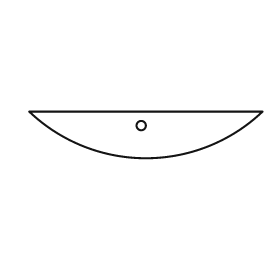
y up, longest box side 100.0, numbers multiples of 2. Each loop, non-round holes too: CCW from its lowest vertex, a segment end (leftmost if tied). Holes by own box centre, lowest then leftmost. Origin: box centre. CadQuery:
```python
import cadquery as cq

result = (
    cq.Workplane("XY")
    .moveTo(-50.0, 10.0)
    .threePointArc((0.0, -10.0), (50.0, 10.0))
    .close()
    .moveTo(-2.0, 4.0)
    .circle(2.0)
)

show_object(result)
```